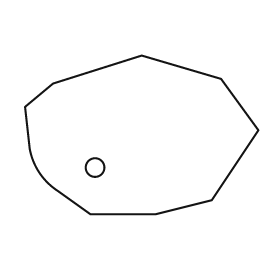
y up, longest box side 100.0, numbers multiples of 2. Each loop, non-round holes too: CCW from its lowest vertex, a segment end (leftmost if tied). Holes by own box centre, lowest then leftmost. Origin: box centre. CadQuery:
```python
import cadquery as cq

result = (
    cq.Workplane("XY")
    .moveTo(-22.0, -34.0)
    .lineTo(6.0, -34.0)
    .lineTo(30.0, -28.0)
    .lineTo(50.0, 2.0)
    .lineTo(34.0, 24.0)
    .lineTo(0.0, 34.0)
    .lineTo(-38.0, 22.0)
    .lineTo(-50.0, 12.0)
    .lineTo(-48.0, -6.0)
    .threePointArc((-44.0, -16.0), (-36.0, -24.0))
    .close()
    .moveTo(-20.0, -14.0)
    .circle(4.0)
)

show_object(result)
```